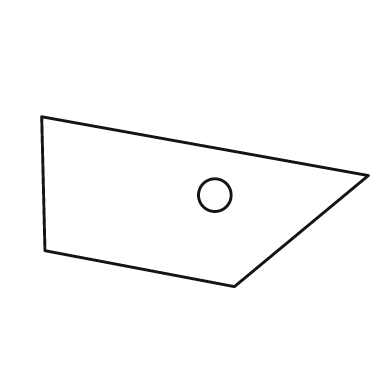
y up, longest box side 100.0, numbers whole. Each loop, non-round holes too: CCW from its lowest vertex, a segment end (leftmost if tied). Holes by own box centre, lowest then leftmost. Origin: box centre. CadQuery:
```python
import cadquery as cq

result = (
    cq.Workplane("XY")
    .moveTo(9.0, -26.0)
    .lineTo(50.0, 8.0)
    .lineTo(-50.0, 26.0)
    .lineTo(-49.0, -15.0)
    .close()
    .moveTo(3.0, 2.0)
    .circle(5.0)
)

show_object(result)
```